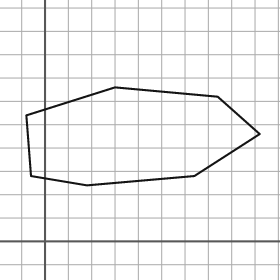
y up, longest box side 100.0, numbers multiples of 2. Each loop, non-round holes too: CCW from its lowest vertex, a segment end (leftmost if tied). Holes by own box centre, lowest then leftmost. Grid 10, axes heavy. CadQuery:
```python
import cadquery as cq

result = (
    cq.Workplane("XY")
    .moveTo(18.0, 24.0)
    .lineTo(64.0, 28.0)
    .lineTo(92.0, 46.0)
    .lineTo(74.0, 62.0)
    .lineTo(30.0, 66.0)
    .lineTo(-8.0, 54.0)
    .lineTo(-6.0, 28.0)
    .close()
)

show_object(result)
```